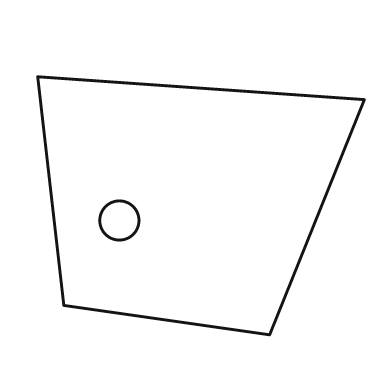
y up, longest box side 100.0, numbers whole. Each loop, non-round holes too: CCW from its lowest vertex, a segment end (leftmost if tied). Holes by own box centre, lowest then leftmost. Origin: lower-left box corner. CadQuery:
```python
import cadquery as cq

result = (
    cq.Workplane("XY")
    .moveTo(71.0, 0.0)
    .lineTo(100.0, 72.0)
    .lineTo(0.0, 79.0)
    .lineTo(8.0, 9.0)
    .close()
    .moveTo(25.0, 35.0)
    .circle(6.0)
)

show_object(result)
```